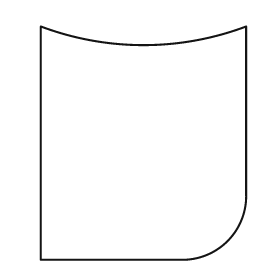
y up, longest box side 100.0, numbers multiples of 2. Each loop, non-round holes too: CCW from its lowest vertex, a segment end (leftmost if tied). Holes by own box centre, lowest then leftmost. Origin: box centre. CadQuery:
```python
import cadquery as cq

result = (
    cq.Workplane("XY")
    .moveTo(-44.0, -50.0)
    .lineTo(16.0, -50.0)
    .threePointArc((36.0, -42.0), (44.0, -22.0))
    .lineTo(44.0, 50.0)
    .threePointArc((0.0, 42.0), (-44.0, 50.0))
    .close()
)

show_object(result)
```